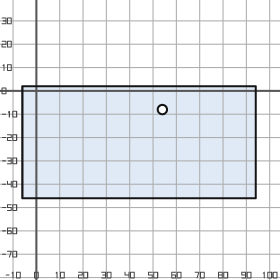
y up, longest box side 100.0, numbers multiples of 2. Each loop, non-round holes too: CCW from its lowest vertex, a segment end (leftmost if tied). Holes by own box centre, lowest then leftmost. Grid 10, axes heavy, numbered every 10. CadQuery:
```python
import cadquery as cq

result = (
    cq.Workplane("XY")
    .moveTo(-6.0, -46.0)
    .lineTo(94.0, -46.0)
    .lineTo(94.0, 2.0)
    .lineTo(-6.0, 2.0)
    .close()
    .moveTo(54.0, -8.0)
    .circle(2.0)
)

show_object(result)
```